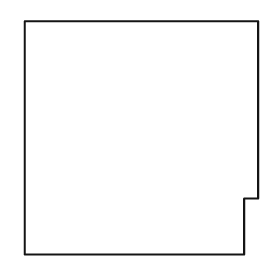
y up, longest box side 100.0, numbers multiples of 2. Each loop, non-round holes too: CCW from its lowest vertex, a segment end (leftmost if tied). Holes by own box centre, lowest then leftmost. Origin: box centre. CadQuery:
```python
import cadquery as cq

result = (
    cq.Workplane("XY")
    .moveTo(-50.0, -50.0)
    .lineTo(44.0, -50.0)
    .lineTo(44.0, -26.0)
    .lineTo(50.0, -26.0)
    .lineTo(50.0, 50.0)
    .lineTo(-50.0, 50.0)
    .close()
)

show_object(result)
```